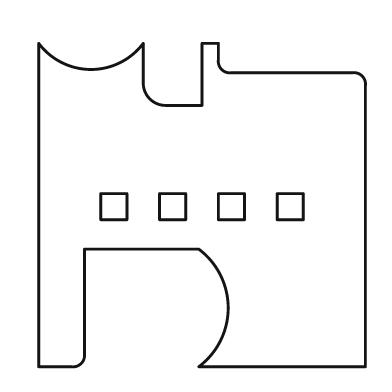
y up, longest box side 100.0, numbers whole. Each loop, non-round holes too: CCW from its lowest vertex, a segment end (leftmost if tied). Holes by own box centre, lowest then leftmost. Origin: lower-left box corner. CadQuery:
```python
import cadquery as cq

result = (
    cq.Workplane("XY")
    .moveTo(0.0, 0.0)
    .lineTo(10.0, 0.0)
    .threePointArc((13.0, 1.0), (14.0, 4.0))
    .lineTo(14.0, 36.0)
    .lineTo(49.0, 36.0)
    .threePointArc((58.0, 18.0), (49.0, 0.0))
    .lineTo(100.0, 0.0)
    .lineTo(100.0, 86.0)
    .threePointArc((99.0, 89.0), (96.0, 90.0))
    .lineTo(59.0, 90.0)
    .threePointArc((56.0, 91.0), (55.0, 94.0))
    .lineTo(55.0, 99.0)
    .lineTo(50.0, 99.0)
    .lineTo(50.0, 80.0)
    .lineTo(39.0, 80.0)
    .threePointArc((34.0, 82.0), (32.0, 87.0))
    .lineTo(32.0, 99.0)
    .threePointArc((16.0, 91.0), (0.0, 99.0))
    .close()
    .moveTo(19.0, 45.0)
    .lineTo(27.0, 45.0)
    .lineTo(27.0, 53.0)
    .lineTo(19.0, 53.0)
    .close()
    .moveTo(37.0, 45.0)
    .lineTo(45.0, 45.0)
    .lineTo(45.0, 53.0)
    .lineTo(37.0, 53.0)
    .close()
    .moveTo(55.0, 45.0)
    .lineTo(63.0, 45.0)
    .lineTo(63.0, 53.0)
    .lineTo(55.0, 53.0)
    .close()
    .moveTo(73.0, 45.0)
    .lineTo(81.0, 45.0)
    .lineTo(81.0, 53.0)
    .lineTo(73.0, 53.0)
    .close()
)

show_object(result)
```